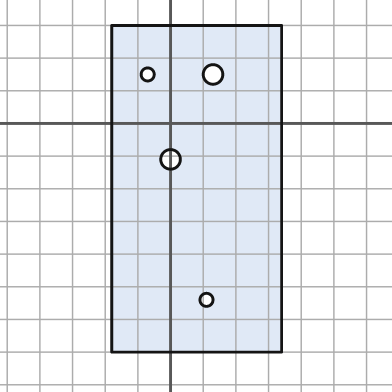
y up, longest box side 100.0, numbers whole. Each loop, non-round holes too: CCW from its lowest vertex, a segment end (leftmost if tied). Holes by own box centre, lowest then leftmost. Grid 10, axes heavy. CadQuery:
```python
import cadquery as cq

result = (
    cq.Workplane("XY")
    .moveTo(-18.0, -70.0)
    .lineTo(34.0, -70.0)
    .lineTo(34.0, 30.0)
    .lineTo(-18.0, 30.0)
    .close()
    .moveTo(11.0, -54.0)
    .circle(2.0)
    .moveTo(0.0, -11.0)
    .circle(3.0)
    .moveTo(-7.0, 15.0)
    .circle(2.0)
    .moveTo(13.0, 15.0)
    .circle(3.0)
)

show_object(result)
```